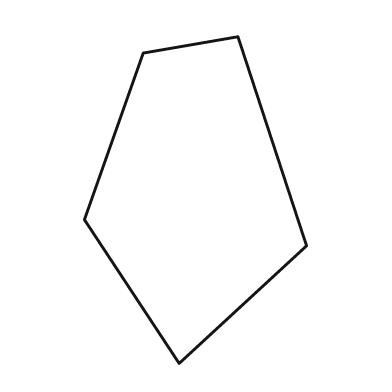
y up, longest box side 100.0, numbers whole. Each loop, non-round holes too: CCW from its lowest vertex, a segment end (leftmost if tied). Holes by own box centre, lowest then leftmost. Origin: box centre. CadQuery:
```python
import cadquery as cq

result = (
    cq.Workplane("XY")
    .moveTo(-5.0, -50.0)
    .lineTo(34.0, -14.0)
    .lineTo(13.0, 50.0)
    .lineTo(-16.0, 45.0)
    .lineTo(-34.0, -6.0)
    .close()
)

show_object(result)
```